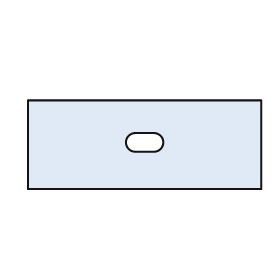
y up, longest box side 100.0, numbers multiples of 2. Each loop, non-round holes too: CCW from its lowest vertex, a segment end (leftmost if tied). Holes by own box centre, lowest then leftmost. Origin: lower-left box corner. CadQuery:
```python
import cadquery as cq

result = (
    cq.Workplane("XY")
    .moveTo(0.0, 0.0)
    .lineTo(100.0, 0.0)
    .lineTo(100.0, 38.0)
    .lineTo(0.0, 38.0)
    .close()
    .moveTo(46.0, 16.0)
    .lineTo(54.0, 16.0)
    .threePointArc((58.0, 20.0), (54.0, 24.0))
    .lineTo(46.0, 24.0)
    .threePointArc((42.0, 20.0), (46.0, 16.0))
    .close()
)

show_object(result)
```